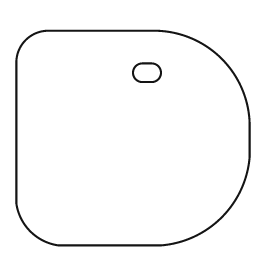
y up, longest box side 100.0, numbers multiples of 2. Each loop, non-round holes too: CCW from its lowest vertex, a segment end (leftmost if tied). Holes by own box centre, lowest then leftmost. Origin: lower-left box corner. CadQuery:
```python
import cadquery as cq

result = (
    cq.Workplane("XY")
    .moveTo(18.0, 0.0)
    .lineTo(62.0, 0.0)
    .threePointArc((88.0, 12.0), (100.0, 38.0))
    .lineTo(100.0, 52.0)
    .threePointArc((88.0, 80.0), (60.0, 92.0))
    .lineTo(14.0, 92.0)
    .threePointArc((4.0, 88.0), (0.0, 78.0))
    .lineTo(0.0, 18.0)
    .threePointArc((6.0, 6.0), (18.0, 0.0))
    .close()
    .moveTo(54.0, 70.0)
    .lineTo(58.0, 70.0)
    .threePointArc((62.0, 74.0), (58.0, 78.0))
    .lineTo(54.0, 78.0)
    .threePointArc((50.0, 74.0), (54.0, 70.0))
    .close()
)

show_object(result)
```